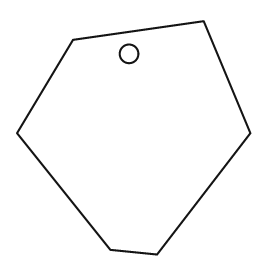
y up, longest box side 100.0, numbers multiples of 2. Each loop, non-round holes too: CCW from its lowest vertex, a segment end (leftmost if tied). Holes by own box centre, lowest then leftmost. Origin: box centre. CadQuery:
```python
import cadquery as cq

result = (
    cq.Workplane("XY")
    .moveTo(10.0, -50.0)
    .lineTo(50.0, 2.0)
    .lineTo(30.0, 50.0)
    .lineTo(-26.0, 42.0)
    .lineTo(-50.0, 2.0)
    .lineTo(-10.0, -48.0)
    .close()
    .moveTo(-2.0, 36.0)
    .circle(4.0)
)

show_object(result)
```